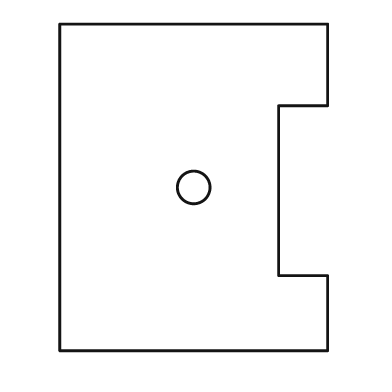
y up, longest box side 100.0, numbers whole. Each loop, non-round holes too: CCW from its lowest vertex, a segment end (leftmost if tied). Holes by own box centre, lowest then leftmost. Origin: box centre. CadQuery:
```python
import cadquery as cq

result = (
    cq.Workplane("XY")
    .moveTo(-41.0, -50.0)
    .lineTo(41.0, -50.0)
    .lineTo(41.0, -27.0)
    .lineTo(26.0, -27.0)
    .lineTo(26.0, 25.0)
    .lineTo(41.0, 25.0)
    .lineTo(41.0, 50.0)
    .lineTo(-41.0, 50.0)
    .close()
    .moveTo(0.0, 0.0)
    .circle(5.0)
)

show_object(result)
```